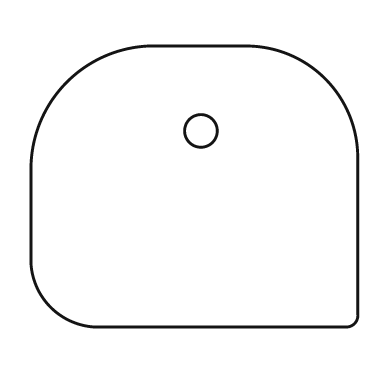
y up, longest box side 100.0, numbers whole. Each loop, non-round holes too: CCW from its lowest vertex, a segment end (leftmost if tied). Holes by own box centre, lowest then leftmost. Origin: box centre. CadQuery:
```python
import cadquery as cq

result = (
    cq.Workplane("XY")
    .moveTo(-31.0, -43.0)
    .lineTo(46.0, -43.0)
    .threePointArc((49.0, -42.0), (50.0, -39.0))
    .lineTo(50.0, 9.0)
    .threePointArc((40.0, 33.0), (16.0, 43.0))
    .lineTo(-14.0, 43.0)
    .threePointArc((-39.0, 32.0), (-50.0, 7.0))
    .lineTo(-50.0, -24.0)
    .threePointArc((-44.0, -37.0), (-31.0, -43.0))
    .close()
    .moveTo(2.0, 17.0)
    .circle(5.0)
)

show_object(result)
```